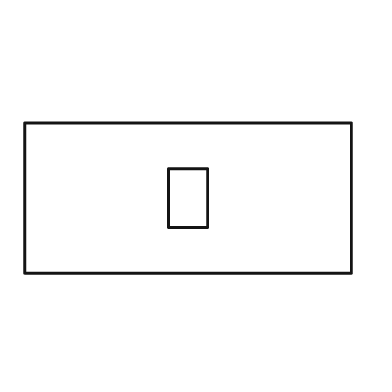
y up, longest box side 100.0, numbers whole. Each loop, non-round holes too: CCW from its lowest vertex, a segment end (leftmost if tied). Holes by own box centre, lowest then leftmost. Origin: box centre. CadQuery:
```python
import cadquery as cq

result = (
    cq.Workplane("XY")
    .moveTo(-50.0, -23.0)
    .lineTo(50.0, -23.0)
    .lineTo(50.0, 23.0)
    .lineTo(-50.0, 23.0)
    .close()
    .moveTo(-6.0, -9.0)
    .lineTo(6.0, -9.0)
    .lineTo(6.0, 9.0)
    .lineTo(-6.0, 9.0)
    .close()
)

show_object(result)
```